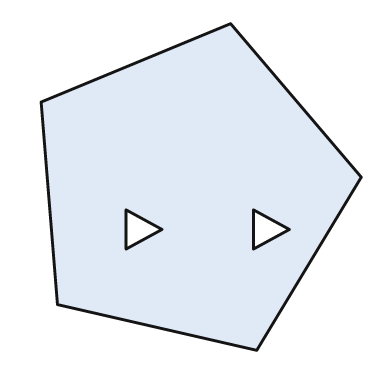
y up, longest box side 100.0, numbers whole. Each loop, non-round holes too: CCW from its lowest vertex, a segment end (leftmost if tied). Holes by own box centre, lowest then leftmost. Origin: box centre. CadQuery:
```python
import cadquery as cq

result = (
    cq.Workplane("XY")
    .moveTo(17.0, -50.0)
    .lineTo(49.0, 3.0)
    .lineTo(9.0, 50.0)
    .lineTo(-49.0, 26.0)
    .lineTo(-44.0, -36.0)
    .close()
    .moveTo(-23.0, -19.0)
    .lineTo(-12.0, -13.0)
    .lineTo(-23.0, -7.0)
    .close()
    .moveTo(16.0, -19.0)
    .lineTo(27.0, -13.0)
    .lineTo(16.0, -7.0)
    .close()
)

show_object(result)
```